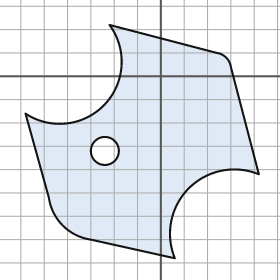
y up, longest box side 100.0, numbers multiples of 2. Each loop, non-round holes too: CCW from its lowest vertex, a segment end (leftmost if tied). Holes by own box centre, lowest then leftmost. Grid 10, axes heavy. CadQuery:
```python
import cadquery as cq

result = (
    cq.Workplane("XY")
    .moveTo(6.0, -78.0)
    .threePointArc((12.0, -48.0), (42.0, -42.0))
    .lineTo(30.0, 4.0)
    .threePointArc((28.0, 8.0), (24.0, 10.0))
    .lineTo(-22.0, 22.0)
    .threePointArc((-24.0, -12.0), (-58.0, -16.0))
    .lineTo(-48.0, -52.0)
    .threePointArc((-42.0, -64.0), (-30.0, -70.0))
    .close()
    .moveTo(-24.0, -32.0)
    .circle(6.0)
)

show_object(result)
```